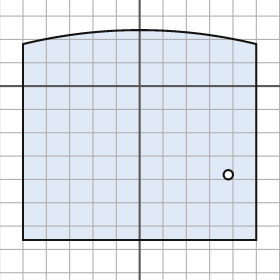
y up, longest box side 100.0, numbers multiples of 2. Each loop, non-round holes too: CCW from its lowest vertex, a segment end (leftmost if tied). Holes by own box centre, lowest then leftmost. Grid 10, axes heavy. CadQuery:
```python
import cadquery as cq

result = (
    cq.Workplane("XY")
    .moveTo(-50.0, -66.0)
    .lineTo(50.0, -66.0)
    .lineTo(50.0, 18.0)
    .threePointArc((0.0, 24.0), (-50.0, 18.0))
    .close()
    .moveTo(38.0, -38.0)
    .circle(2.0)
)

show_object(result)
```